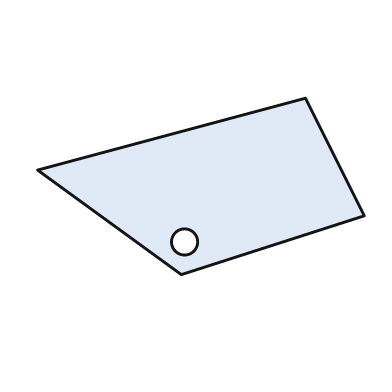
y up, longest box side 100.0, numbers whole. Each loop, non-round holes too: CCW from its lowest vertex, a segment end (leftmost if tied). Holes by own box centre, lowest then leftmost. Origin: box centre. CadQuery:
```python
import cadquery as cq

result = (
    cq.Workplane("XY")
    .moveTo(-6.0, -27.0)
    .lineTo(50.0, -9.0)
    .lineTo(32.0, 27.0)
    .lineTo(-50.0, 5.0)
    .close()
    .moveTo(-5.0, -17.0)
    .circle(4.0)
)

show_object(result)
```